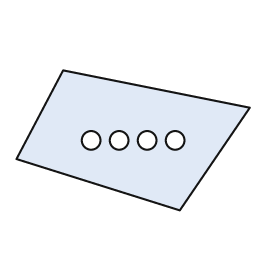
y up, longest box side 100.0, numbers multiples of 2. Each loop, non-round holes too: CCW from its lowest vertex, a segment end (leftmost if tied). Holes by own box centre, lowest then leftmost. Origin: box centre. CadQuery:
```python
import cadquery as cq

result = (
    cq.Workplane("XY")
    .moveTo(20.0, -30.0)
    .lineTo(50.0, 14.0)
    .lineTo(-30.0, 30.0)
    .lineTo(-50.0, -8.0)
    .close()
    .moveTo(-18.0, 0.0)
    .circle(4.0)
    .moveTo(-6.0, 0.0)
    .circle(4.0)
    .moveTo(6.0, 0.0)
    .circle(4.0)
    .moveTo(18.0, 0.0)
    .circle(4.0)
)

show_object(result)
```